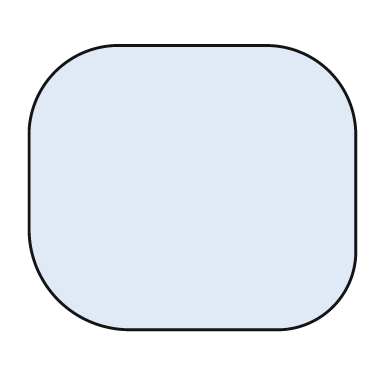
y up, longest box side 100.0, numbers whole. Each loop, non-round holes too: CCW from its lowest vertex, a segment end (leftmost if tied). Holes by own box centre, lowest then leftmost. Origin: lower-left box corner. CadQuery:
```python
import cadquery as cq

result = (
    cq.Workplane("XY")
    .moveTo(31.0, 0.0)
    .lineTo(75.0, 0.0)
    .threePointArc((93.0, 7.0), (100.0, 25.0))
    .lineTo(100.0, 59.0)
    .threePointArc((92.0, 79.0), (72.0, 87.0))
    .lineTo(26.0, 87.0)
    .threePointArc((8.0, 79.0), (0.0, 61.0))
    .lineTo(0.0, 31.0)
    .threePointArc((9.0, 9.0), (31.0, 0.0))
    .close()
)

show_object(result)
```